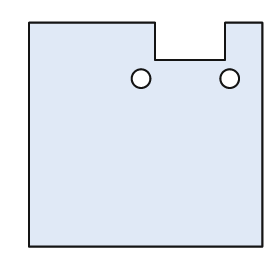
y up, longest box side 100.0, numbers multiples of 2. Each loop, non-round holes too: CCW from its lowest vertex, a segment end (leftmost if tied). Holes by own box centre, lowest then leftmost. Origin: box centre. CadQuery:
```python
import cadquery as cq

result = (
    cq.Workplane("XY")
    .moveTo(-50.0, -48.0)
    .lineTo(50.0, -48.0)
    .lineTo(50.0, 48.0)
    .lineTo(34.0, 48.0)
    .lineTo(34.0, 32.0)
    .lineTo(4.0, 32.0)
    .lineTo(4.0, 48.0)
    .lineTo(-50.0, 48.0)
    .close()
    .moveTo(-2.0, 24.0)
    .circle(4.0)
    .moveTo(36.0, 24.0)
    .circle(4.0)
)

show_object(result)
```